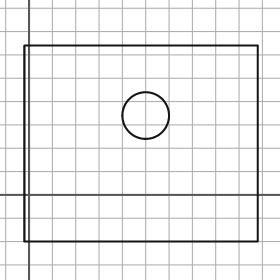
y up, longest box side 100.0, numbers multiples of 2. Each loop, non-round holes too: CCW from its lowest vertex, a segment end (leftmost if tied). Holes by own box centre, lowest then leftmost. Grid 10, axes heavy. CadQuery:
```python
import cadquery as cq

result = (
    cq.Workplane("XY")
    .moveTo(-2.0, -20.0)
    .lineTo(98.0, -20.0)
    .lineTo(98.0, 64.0)
    .lineTo(-2.0, 64.0)
    .close()
    .moveTo(50.0, 34.0)
    .circle(10.0)
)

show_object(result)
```